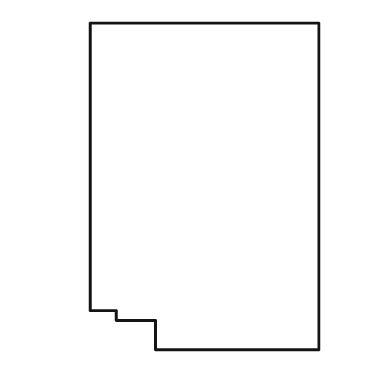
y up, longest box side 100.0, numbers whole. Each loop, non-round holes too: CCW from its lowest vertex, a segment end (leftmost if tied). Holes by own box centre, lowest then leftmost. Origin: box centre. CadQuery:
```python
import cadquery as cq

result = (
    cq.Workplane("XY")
    .moveTo(-15.0, -50.0)
    .lineTo(35.0, -50.0)
    .lineTo(35.0, 50.0)
    .lineTo(-35.0, 50.0)
    .lineTo(-35.0, -38.0)
    .lineTo(-27.0, -38.0)
    .lineTo(-27.0, -41.0)
    .lineTo(-15.0, -41.0)
    .close()
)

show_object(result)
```